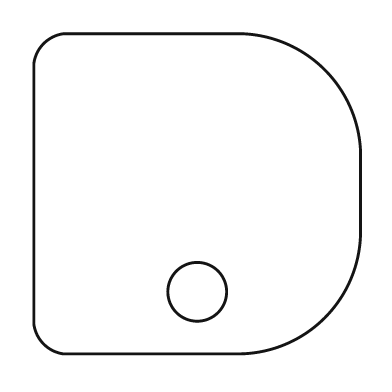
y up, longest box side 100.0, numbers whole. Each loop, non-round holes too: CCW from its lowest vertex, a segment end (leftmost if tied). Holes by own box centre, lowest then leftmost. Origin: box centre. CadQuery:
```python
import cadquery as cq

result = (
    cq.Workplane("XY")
    .moveTo(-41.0, -49.0)
    .lineTo(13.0, -49.0)
    .threePointArc((39.0, -38.0), (50.0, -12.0))
    .lineTo(50.0, 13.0)
    .threePointArc((39.0, 38.0), (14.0, 49.0))
    .lineTo(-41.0, 49.0)
    .threePointArc((-47.0, 46.0), (-50.0, 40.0))
    .lineTo(-50.0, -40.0)
    .threePointArc((-47.0, -46.0), (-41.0, -49.0))
    .close()
    .moveTo(0.0, -30.0)
    .circle(9.0)
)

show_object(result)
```